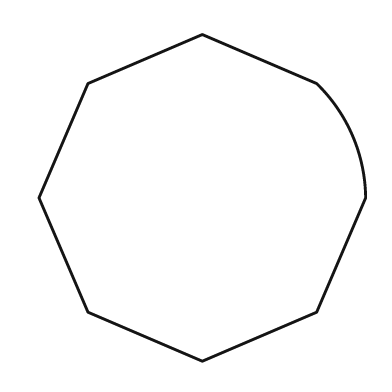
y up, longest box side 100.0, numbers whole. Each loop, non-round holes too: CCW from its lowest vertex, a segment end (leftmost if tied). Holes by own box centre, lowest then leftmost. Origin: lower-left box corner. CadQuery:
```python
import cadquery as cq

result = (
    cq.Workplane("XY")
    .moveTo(50.0, 0.0)
    .lineTo(85.0, 15.0)
    .lineTo(100.0, 50.0)
    .threePointArc((96.0, 69.0), (85.0, 85.0))
    .lineTo(50.0, 100.0)
    .lineTo(15.0, 85.0)
    .lineTo(0.0, 50.0)
    .lineTo(15.0, 15.0)
    .close()
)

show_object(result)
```